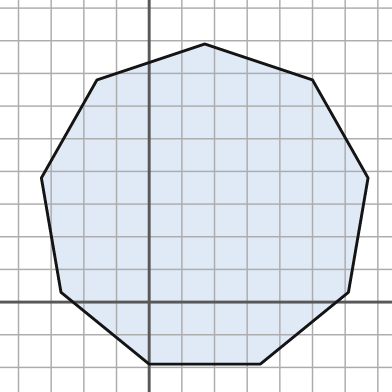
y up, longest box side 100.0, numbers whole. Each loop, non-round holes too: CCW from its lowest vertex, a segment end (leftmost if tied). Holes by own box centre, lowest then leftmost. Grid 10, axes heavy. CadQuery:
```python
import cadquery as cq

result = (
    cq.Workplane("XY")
    .moveTo(0.0, -19.0)
    .lineTo(34.0, -19.0)
    .lineTo(61.0, 3.0)
    .lineTo(67.0, 38.0)
    .lineTo(50.0, 68.0)
    .lineTo(17.0, 79.0)
    .lineTo(-16.0, 68.0)
    .lineTo(-33.0, 38.0)
    .lineTo(-27.0, 3.0)
    .close()
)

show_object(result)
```